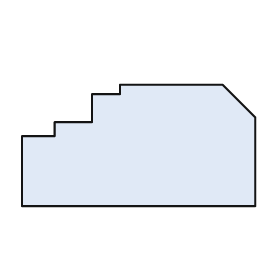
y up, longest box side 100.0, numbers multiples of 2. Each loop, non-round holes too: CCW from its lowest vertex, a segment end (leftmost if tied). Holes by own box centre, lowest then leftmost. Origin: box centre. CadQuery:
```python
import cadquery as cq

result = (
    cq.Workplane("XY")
    .moveTo(-50.0, -26.0)
    .lineTo(50.0, -26.0)
    .lineTo(50.0, 12.0)
    .lineTo(36.0, 26.0)
    .lineTo(-8.0, 26.0)
    .lineTo(-8.0, 22.0)
    .lineTo(-20.0, 22.0)
    .lineTo(-20.0, 10.0)
    .lineTo(-36.0, 10.0)
    .lineTo(-36.0, 4.0)
    .lineTo(-50.0, 4.0)
    .close()
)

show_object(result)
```